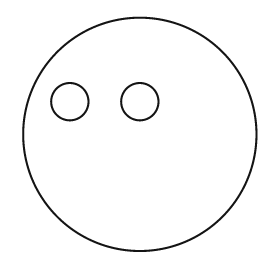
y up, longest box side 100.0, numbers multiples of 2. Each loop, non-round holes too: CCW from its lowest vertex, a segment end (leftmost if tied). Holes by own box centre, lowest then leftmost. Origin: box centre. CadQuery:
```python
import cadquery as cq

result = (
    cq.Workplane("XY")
    .moveTo(0.0, 0.0)
    .circle(50.0)
    .moveTo(-30.0, 14.0)
    .circle(8.0)
    .moveTo(0.0, 14.0)
    .circle(8.0)
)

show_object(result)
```